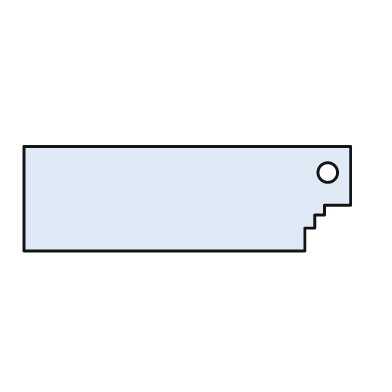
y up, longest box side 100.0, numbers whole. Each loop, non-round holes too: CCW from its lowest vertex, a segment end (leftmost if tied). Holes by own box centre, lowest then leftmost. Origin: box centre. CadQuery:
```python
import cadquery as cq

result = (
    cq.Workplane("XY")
    .moveTo(-50.0, -16.0)
    .lineTo(36.0, -16.0)
    .lineTo(36.0, -9.0)
    .lineTo(39.0, -9.0)
    .lineTo(39.0, -5.0)
    .lineTo(42.0, -5.0)
    .lineTo(42.0, -2.0)
    .lineTo(50.0, -2.0)
    .lineTo(50.0, 16.0)
    .lineTo(-50.0, 16.0)
    .close()
    .moveTo(43.0, 8.0)
    .circle(3.0)
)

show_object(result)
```